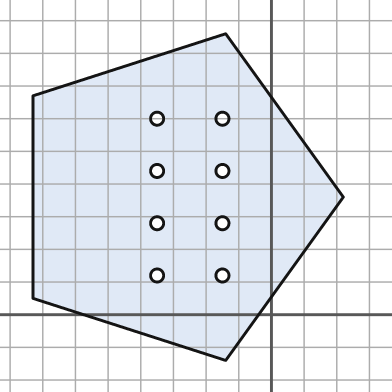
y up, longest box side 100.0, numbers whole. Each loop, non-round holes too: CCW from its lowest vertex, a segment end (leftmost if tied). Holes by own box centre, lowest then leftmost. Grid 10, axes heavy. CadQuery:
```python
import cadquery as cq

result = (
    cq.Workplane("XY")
    .moveTo(-14.0, -14.0)
    .lineTo(22.0, 36.0)
    .lineTo(-14.0, 86.0)
    .lineTo(-73.0, 67.0)
    .lineTo(-73.0, 5.0)
    .close()
    .moveTo(-35.0, 12.0)
    .circle(2.0)
    .moveTo(-15.0, 12.0)
    .circle(2.0)
    .moveTo(-35.0, 28.0)
    .circle(2.0)
    .moveTo(-15.0, 28.0)
    .circle(2.0)
    .moveTo(-35.0, 44.0)
    .circle(2.0)
    .moveTo(-15.0, 44.0)
    .circle(2.0)
    .moveTo(-35.0, 60.0)
    .circle(2.0)
    .moveTo(-15.0, 60.0)
    .circle(2.0)
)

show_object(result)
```